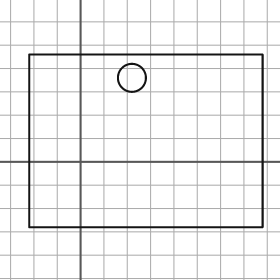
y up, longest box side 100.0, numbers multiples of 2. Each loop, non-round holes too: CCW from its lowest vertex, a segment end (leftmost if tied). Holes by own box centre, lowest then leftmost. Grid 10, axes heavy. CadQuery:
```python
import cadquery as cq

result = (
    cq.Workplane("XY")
    .moveTo(-22.0, -28.0)
    .lineTo(78.0, -28.0)
    .lineTo(78.0, 46.0)
    .lineTo(-22.0, 46.0)
    .close()
    .moveTo(22.0, 36.0)
    .circle(6.0)
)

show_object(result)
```